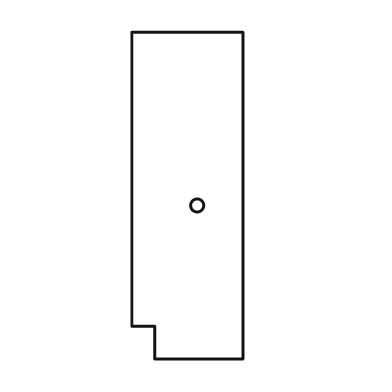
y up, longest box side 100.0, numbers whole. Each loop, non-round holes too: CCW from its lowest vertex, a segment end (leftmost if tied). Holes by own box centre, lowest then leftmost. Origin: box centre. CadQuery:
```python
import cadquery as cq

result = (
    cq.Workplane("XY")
    .moveTo(-10.0, -50.0)
    .lineTo(17.0, -50.0)
    .lineTo(17.0, 50.0)
    .lineTo(-17.0, 50.0)
    .lineTo(-17.0, -40.0)
    .lineTo(-10.0, -40.0)
    .close()
    .moveTo(3.0, -3.0)
    .circle(2.0)
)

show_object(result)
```